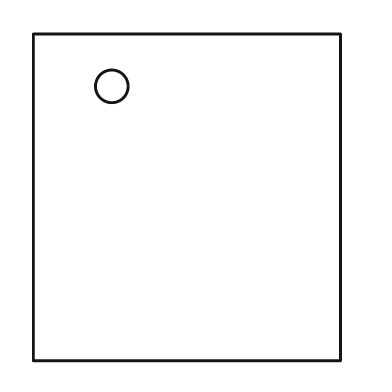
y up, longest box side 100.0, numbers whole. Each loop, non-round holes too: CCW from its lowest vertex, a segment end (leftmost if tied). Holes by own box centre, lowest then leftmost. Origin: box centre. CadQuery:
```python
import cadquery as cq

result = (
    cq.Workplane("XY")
    .moveTo(-47.0, -50.0)
    .lineTo(47.0, -50.0)
    .lineTo(47.0, 50.0)
    .lineTo(-47.0, 50.0)
    .close()
    .moveTo(-23.0, 34.0)
    .circle(5.0)
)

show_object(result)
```